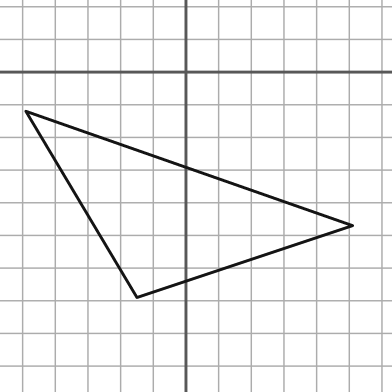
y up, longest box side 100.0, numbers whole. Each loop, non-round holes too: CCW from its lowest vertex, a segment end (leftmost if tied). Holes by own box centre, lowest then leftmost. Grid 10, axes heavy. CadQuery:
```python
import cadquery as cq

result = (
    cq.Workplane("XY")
    .moveTo(-15.0, -69.0)
    .lineTo(51.0, -47.0)
    .lineTo(-49.0, -12.0)
    .close()
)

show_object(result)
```